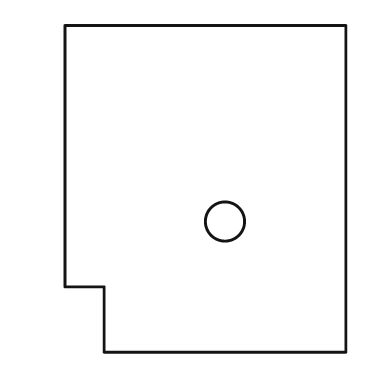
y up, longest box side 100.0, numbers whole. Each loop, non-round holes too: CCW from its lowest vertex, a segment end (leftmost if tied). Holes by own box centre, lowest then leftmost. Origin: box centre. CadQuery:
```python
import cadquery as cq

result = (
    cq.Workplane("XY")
    .moveTo(-31.0, -50.0)
    .lineTo(43.0, -50.0)
    .lineTo(43.0, 50.0)
    .lineTo(-43.0, 50.0)
    .lineTo(-43.0, -30.0)
    .lineTo(-31.0, -30.0)
    .close()
    .moveTo(6.0, -10.0)
    .circle(6.0)
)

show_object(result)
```